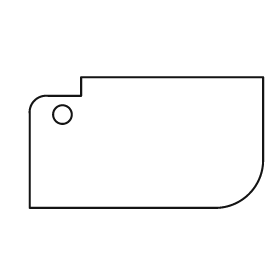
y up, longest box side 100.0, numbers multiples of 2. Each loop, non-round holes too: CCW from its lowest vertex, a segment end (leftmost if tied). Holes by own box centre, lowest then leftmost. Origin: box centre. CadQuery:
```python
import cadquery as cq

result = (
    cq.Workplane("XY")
    .moveTo(-50.0, -28.0)
    .lineTo(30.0, -28.0)
    .threePointArc((44.0, -22.0), (50.0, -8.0))
    .lineTo(50.0, 28.0)
    .lineTo(-28.0, 28.0)
    .lineTo(-28.0, 20.0)
    .lineTo(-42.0, 20.0)
    .threePointArc((-48.0, 18.0), (-50.0, 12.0))
    .close()
    .moveTo(-36.0, 12.0)
    .circle(4.0)
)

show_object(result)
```